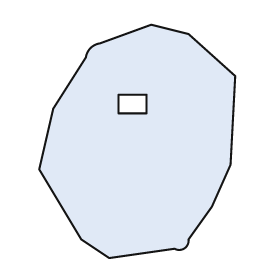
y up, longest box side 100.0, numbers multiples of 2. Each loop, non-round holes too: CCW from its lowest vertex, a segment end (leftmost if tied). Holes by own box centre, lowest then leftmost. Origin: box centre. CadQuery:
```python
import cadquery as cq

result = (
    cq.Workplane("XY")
    .moveTo(-12.0, -50.0)
    .lineTo(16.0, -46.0)
    .threePointArc((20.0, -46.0), (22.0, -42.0))
    .lineTo(32.0, -28.0)
    .lineTo(40.0, -10.0)
    .lineTo(42.0, 28.0)
    .lineTo(22.0, 46.0)
    .lineTo(6.0, 50.0)
    .lineTo(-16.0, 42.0)
    .threePointArc((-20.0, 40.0), (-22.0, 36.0))
    .lineTo(-36.0, 14.0)
    .lineTo(-42.0, -12.0)
    .lineTo(-24.0, -42.0)
    .close()
    .moveTo(-8.0, 12.0)
    .lineTo(4.0, 12.0)
    .lineTo(4.0, 20.0)
    .lineTo(-8.0, 20.0)
    .close()
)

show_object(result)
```